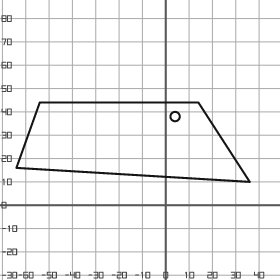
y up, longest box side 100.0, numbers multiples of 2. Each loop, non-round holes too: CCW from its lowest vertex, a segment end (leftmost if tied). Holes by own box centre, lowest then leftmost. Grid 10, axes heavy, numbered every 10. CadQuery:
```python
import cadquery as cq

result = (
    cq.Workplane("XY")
    .moveTo(36.0, 10.0)
    .lineTo(14.0, 44.0)
    .lineTo(-54.0, 44.0)
    .lineTo(-64.0, 16.0)
    .close()
    .moveTo(4.0, 38.0)
    .circle(2.0)
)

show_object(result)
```